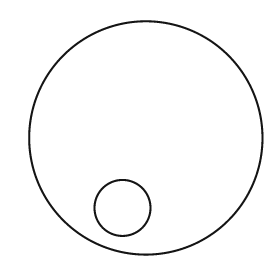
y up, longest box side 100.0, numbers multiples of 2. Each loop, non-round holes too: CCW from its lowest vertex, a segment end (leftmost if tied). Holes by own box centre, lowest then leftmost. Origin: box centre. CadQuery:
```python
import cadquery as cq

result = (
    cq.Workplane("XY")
    .moveTo(0.0, 0.0)
    .circle(50.0)
    .moveTo(-10.0, -30.0)
    .circle(12.0)
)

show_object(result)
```